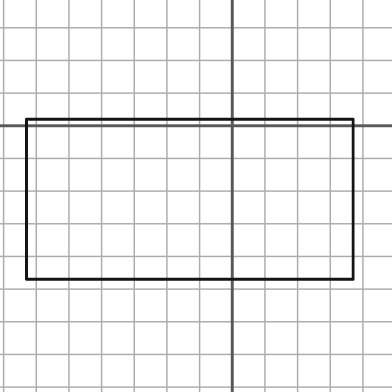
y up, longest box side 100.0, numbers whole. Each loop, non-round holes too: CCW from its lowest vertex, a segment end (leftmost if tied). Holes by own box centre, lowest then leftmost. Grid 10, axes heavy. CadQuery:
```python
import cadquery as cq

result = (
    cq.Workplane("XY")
    .moveTo(-63.0, -47.0)
    .lineTo(37.0, -47.0)
    .lineTo(37.0, 2.0)
    .lineTo(-63.0, 2.0)
    .close()
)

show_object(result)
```